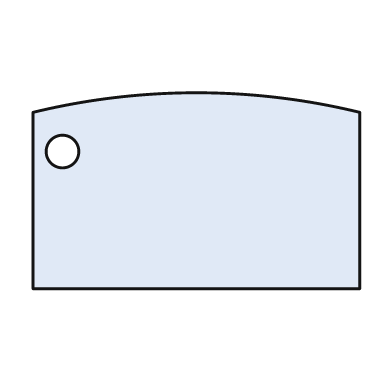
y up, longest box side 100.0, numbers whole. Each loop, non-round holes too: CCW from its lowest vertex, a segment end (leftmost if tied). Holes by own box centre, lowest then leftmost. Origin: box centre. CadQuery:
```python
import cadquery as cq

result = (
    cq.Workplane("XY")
    .moveTo(-50.0, -30.0)
    .lineTo(50.0, -30.0)
    .lineTo(50.0, 24.0)
    .threePointArc((0.0, 30.0), (-50.0, 24.0))
    .close()
    .moveTo(-41.0, 12.0)
    .circle(5.0)
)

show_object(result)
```